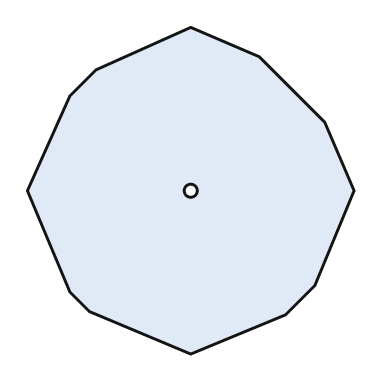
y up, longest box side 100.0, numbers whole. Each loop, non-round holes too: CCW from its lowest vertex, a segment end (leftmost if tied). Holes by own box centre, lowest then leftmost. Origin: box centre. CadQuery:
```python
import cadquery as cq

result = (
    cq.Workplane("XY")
    .moveTo(0.0, -50.0)
    .lineTo(29.0, -38.0)
    .lineTo(38.0, -29.0)
    .lineTo(50.0, 0.0)
    .lineTo(41.0, 21.0)
    .lineTo(21.0, 41.0)
    .lineTo(0.0, 50.0)
    .lineTo(-29.0, 37.0)
    .lineTo(-37.0, 29.0)
    .lineTo(-50.0, 0.0)
    .lineTo(-37.0, -31.0)
    .lineTo(-31.0, -37.0)
    .close()
    .moveTo(0.0, 0.0)
    .circle(2.0)
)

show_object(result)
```